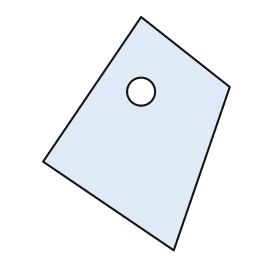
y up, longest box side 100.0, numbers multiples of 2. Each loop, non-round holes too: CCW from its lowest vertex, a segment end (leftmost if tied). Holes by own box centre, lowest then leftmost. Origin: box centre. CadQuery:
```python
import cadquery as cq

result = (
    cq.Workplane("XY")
    .moveTo(16.0, -50.0)
    .lineTo(40.0, 20.0)
    .lineTo(2.0, 50.0)
    .lineTo(-40.0, -12.0)
    .close()
    .moveTo(2.0, 18.0)
    .circle(6.0)
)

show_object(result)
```